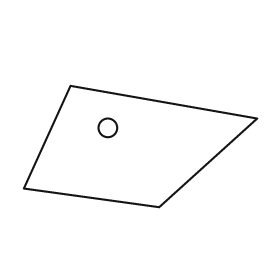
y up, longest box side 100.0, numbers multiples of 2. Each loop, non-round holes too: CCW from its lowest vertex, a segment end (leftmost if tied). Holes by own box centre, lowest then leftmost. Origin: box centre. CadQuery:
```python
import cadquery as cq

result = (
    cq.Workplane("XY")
    .moveTo(8.0, -26.0)
    .lineTo(50.0, 12.0)
    .lineTo(-30.0, 26.0)
    .lineTo(-50.0, -18.0)
    .close()
    .moveTo(-14.0, 8.0)
    .circle(4.0)
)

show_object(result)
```